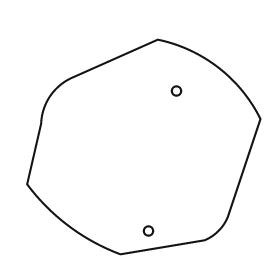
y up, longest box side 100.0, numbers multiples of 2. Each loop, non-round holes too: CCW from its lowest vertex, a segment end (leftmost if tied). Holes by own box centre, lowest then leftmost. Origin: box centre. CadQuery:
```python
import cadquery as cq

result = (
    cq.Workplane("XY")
    .moveTo(-10.0, -46.0)
    .lineTo(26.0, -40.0)
    .threePointArc((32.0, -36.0), (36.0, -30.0))
    .lineTo(50.0, 12.0)
    .threePointArc((32.0, 34.0), (6.0, 46.0))
    .lineTo(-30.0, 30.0)
    .threePointArc((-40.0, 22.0), (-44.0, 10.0))
    .lineTo(-50.0, -16.0)
    .threePointArc((-32.0, -34.0), (-10.0, -46.0))
    .close()
    .moveTo(2.0, -36.0)
    .circle(2.0)
    .moveTo(14.0, 24.0)
    .circle(2.0)
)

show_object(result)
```